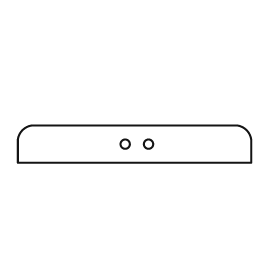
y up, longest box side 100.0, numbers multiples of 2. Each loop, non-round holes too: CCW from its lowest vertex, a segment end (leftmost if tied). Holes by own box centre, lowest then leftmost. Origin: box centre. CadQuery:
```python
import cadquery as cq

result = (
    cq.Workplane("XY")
    .moveTo(-50.0, -8.0)
    .lineTo(50.0, -8.0)
    .lineTo(50.0, 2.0)
    .threePointArc((48.0, 6.0), (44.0, 8.0))
    .lineTo(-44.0, 8.0)
    .threePointArc((-48.0, 6.0), (-50.0, 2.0))
    .close()
    .moveTo(-4.0, 0.0)
    .circle(2.0)
    .moveTo(6.0, 0.0)
    .circle(2.0)
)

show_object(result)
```